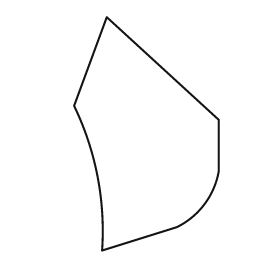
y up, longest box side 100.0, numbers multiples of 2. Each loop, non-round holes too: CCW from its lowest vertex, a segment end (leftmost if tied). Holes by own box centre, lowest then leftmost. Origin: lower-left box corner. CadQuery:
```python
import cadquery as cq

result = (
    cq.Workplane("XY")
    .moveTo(12.0, 0.0)
    .lineTo(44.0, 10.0)
    .threePointArc((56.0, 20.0), (62.0, 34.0))
    .lineTo(62.0, 56.0)
    .lineTo(14.0, 100.0)
    .lineTo(0.0, 62.0)
    .threePointArc((10.0, 32.0), (12.0, 0.0))
    .close()
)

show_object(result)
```